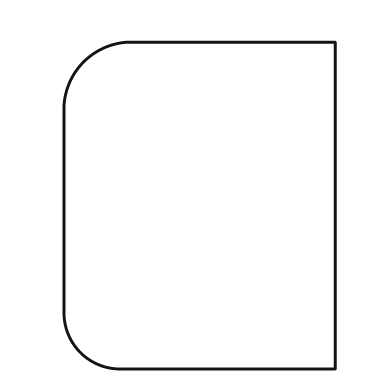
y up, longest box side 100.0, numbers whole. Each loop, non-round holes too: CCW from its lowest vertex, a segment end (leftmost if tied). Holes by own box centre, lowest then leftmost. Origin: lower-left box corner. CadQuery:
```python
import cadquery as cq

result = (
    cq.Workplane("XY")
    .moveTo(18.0, 0.0)
    .lineTo(83.0, 0.0)
    .lineTo(83.0, 100.0)
    .lineTo(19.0, 100.0)
    .threePointArc((6.0, 94.0), (0.0, 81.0))
    .lineTo(0.0, 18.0)
    .threePointArc((5.0, 5.0), (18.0, 0.0))
    .close()
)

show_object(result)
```